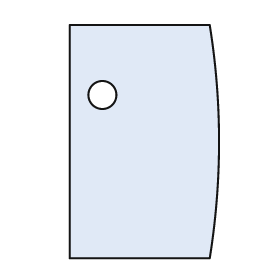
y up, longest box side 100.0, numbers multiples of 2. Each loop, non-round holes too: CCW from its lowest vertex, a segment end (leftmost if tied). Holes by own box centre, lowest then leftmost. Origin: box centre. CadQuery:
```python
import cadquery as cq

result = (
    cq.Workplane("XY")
    .moveTo(-32.0, -50.0)
    .lineTo(28.0, -50.0)
    .threePointArc((32.0, 0.0), (28.0, 50.0))
    .lineTo(-32.0, 50.0)
    .close()
    .moveTo(-18.0, 20.0)
    .circle(6.0)
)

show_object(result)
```